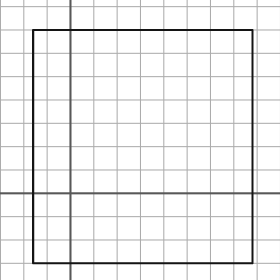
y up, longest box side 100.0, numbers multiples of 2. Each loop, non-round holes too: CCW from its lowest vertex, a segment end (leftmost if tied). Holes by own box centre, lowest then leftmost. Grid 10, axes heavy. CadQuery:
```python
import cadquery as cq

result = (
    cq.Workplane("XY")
    .moveTo(-16.0, -30.0)
    .lineTo(78.0, -30.0)
    .lineTo(78.0, 70.0)
    .lineTo(-16.0, 70.0)
    .close()
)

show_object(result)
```